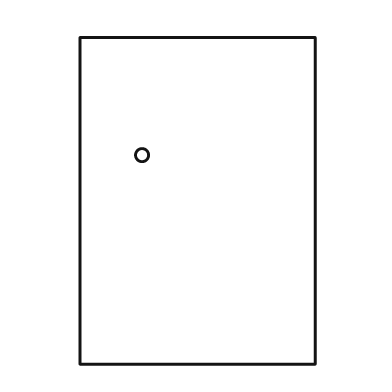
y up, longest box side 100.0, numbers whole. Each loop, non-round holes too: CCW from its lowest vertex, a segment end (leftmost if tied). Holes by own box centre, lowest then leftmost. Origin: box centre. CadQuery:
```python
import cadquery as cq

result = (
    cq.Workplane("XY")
    .moveTo(-36.0, -50.0)
    .lineTo(36.0, -50.0)
    .lineTo(36.0, 50.0)
    .lineTo(-36.0, 50.0)
    .close()
    .moveTo(-17.0, 14.0)
    .circle(2.0)
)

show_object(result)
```